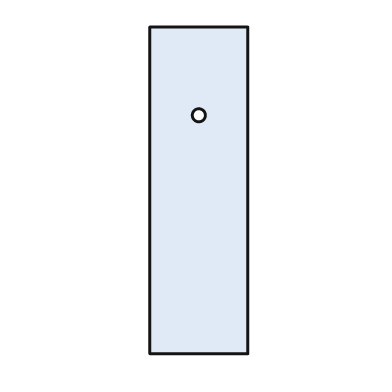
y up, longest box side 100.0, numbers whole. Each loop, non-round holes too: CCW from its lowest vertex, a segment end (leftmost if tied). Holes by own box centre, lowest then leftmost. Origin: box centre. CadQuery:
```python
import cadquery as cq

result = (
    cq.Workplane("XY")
    .moveTo(-15.0, -50.0)
    .lineTo(15.0, -50.0)
    .lineTo(15.0, 50.0)
    .lineTo(-15.0, 50.0)
    .close()
    .moveTo(0.0, 23.0)
    .circle(2.0)
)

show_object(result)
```